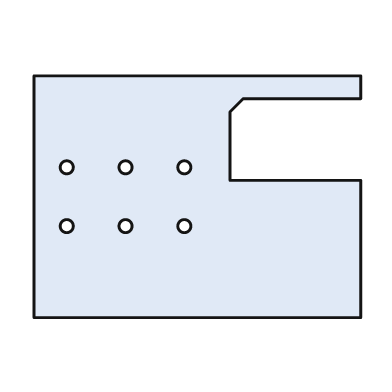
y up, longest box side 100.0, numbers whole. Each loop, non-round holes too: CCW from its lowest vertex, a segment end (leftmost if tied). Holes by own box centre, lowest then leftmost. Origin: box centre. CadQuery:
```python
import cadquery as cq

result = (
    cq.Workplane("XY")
    .moveTo(-50.0, -37.0)
    .lineTo(50.0, -37.0)
    .lineTo(50.0, 5.0)
    .lineTo(10.0, 5.0)
    .lineTo(10.0, 26.0)
    .lineTo(14.0, 30.0)
    .lineTo(50.0, 30.0)
    .lineTo(50.0, 37.0)
    .lineTo(-50.0, 37.0)
    .close()
    .moveTo(-40.0, -9.0)
    .circle(2.0)
    .moveTo(-22.0, -9.0)
    .circle(2.0)
    .moveTo(-4.0, -9.0)
    .circle(2.0)
    .moveTo(-40.0, 9.0)
    .circle(2.0)
    .moveTo(-22.0, 9.0)
    .circle(2.0)
    .moveTo(-4.0, 9.0)
    .circle(2.0)
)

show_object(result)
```